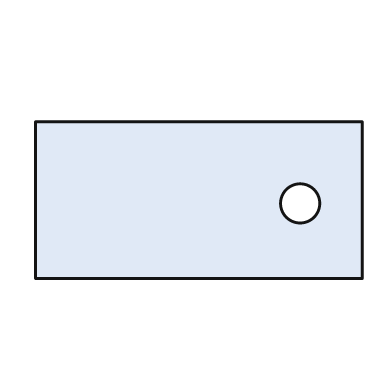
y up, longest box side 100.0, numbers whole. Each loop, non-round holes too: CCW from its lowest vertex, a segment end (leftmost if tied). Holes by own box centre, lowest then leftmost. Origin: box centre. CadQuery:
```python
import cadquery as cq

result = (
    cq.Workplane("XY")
    .moveTo(-50.0, -24.0)
    .lineTo(50.0, -24.0)
    .lineTo(50.0, 24.0)
    .lineTo(-50.0, 24.0)
    .close()
    .moveTo(31.0, -1.0)
    .circle(6.0)
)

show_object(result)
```